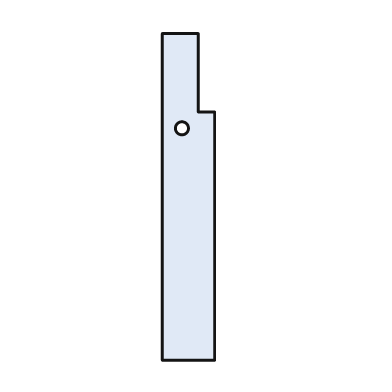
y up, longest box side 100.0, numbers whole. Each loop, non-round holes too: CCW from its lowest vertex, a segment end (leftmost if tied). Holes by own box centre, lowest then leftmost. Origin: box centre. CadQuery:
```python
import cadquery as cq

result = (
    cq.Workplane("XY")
    .moveTo(-8.0, -50.0)
    .lineTo(8.0, -50.0)
    .lineTo(8.0, 26.0)
    .lineTo(3.0, 26.0)
    .lineTo(3.0, 50.0)
    .lineTo(-8.0, 50.0)
    .close()
    .moveTo(-2.0, 21.0)
    .circle(2.0)
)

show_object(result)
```